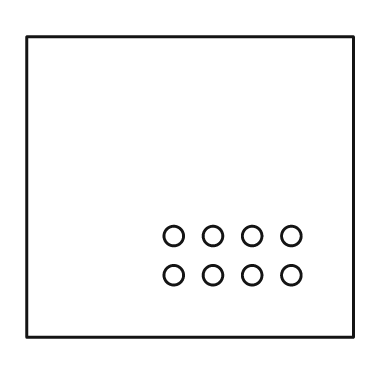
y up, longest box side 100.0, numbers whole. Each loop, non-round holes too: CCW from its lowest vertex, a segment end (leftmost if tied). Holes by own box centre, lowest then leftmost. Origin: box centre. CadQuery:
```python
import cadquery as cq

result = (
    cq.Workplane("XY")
    .moveTo(-50.0, -46.0)
    .lineTo(50.0, -46.0)
    .lineTo(50.0, 46.0)
    .lineTo(-50.0, 46.0)
    .close()
    .moveTo(-5.0, -27.0)
    .circle(3.0)
    .moveTo(7.0, -27.0)
    .circle(3.0)
    .moveTo(19.0, -27.0)
    .circle(3.0)
    .moveTo(31.0, -27.0)
    .circle(3.0)
    .moveTo(-5.0, -15.0)
    .circle(3.0)
    .moveTo(7.0, -15.0)
    .circle(3.0)
    .moveTo(19.0, -15.0)
    .circle(3.0)
    .moveTo(31.0, -15.0)
    .circle(3.0)
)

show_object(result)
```